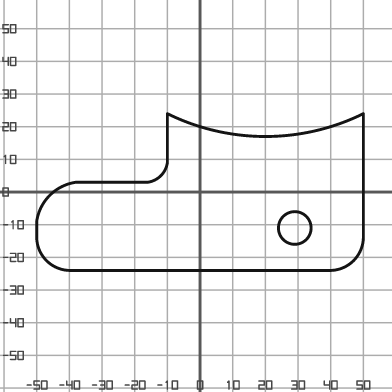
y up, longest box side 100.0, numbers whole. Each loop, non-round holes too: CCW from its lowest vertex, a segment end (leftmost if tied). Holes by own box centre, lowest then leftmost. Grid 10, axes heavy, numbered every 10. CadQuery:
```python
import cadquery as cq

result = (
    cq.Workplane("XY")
    .moveTo(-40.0, -24.0)
    .lineTo(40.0, -24.0)
    .threePointArc((47.0, -21.0), (50.0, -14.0))
    .lineTo(50.0, 24.0)
    .threePointArc((20.0, 17.0), (-10.0, 24.0))
    .lineTo(-10.0, 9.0)
    .threePointArc((-12.0, 5.0), (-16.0, 3.0))
    .lineTo(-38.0, 3.0)
    .threePointArc((-46.0, -1.0), (-50.0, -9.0))
    .lineTo(-50.0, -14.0)
    .threePointArc((-47.0, -21.0), (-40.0, -24.0))
    .close()
    .moveTo(29.0, -11.0)
    .circle(5.0)
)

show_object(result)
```